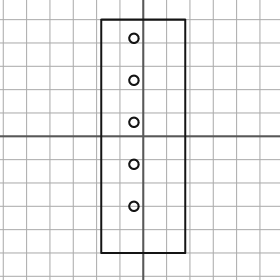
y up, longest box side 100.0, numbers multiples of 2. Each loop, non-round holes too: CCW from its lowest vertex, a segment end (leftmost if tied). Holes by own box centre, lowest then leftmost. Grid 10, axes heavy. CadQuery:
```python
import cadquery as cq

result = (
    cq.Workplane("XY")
    .moveTo(-18.0, -50.0)
    .lineTo(18.0, -50.0)
    .lineTo(18.0, 50.0)
    .lineTo(-18.0, 50.0)
    .close()
    .moveTo(-4.0, -30.0)
    .circle(2.0)
    .moveTo(-4.0, -12.0)
    .circle(2.0)
    .moveTo(-4.0, 6.0)
    .circle(2.0)
    .moveTo(-4.0, 24.0)
    .circle(2.0)
    .moveTo(-4.0, 42.0)
    .circle(2.0)
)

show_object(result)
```